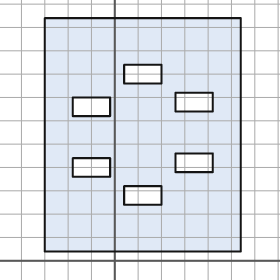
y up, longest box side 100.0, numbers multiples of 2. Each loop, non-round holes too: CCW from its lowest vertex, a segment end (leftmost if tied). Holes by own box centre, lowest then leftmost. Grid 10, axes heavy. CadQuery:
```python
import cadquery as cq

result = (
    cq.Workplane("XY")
    .moveTo(-30.0, 4.0)
    .lineTo(54.0, 4.0)
    .lineTo(54.0, 104.0)
    .lineTo(-30.0, 104.0)
    .close()
    .moveTo(4.0, 24.0)
    .lineTo(20.0, 24.0)
    .lineTo(20.0, 32.0)
    .lineTo(4.0, 32.0)
    .close()
    .moveTo(-18.0, 36.0)
    .lineTo(-2.0, 36.0)
    .lineTo(-2.0, 44.0)
    .lineTo(-18.0, 44.0)
    .close()
    .moveTo(26.0, 38.0)
    .lineTo(42.0, 38.0)
    .lineTo(42.0, 46.0)
    .lineTo(26.0, 46.0)
    .close()
    .moveTo(-18.0, 62.0)
    .lineTo(-2.0, 62.0)
    .lineTo(-2.0, 70.0)
    .lineTo(-18.0, 70.0)
    .close()
    .moveTo(26.0, 64.0)
    .lineTo(42.0, 64.0)
    .lineTo(42.0, 72.0)
    .lineTo(26.0, 72.0)
    .close()
    .moveTo(4.0, 76.0)
    .lineTo(20.0, 76.0)
    .lineTo(20.0, 84.0)
    .lineTo(4.0, 84.0)
    .close()
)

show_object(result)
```